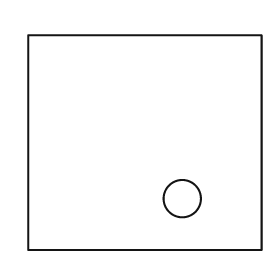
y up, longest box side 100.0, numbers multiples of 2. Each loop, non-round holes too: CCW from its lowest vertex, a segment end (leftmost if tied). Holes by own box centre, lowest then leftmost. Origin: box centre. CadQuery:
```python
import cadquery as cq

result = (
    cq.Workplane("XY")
    .moveTo(-50.0, -46.0)
    .lineTo(50.0, -46.0)
    .lineTo(50.0, 46.0)
    .lineTo(-50.0, 46.0)
    .close()
    .moveTo(16.0, -24.0)
    .circle(8.0)
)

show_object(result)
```